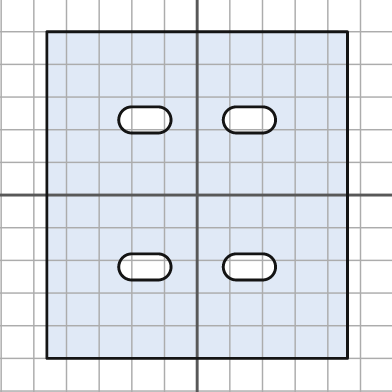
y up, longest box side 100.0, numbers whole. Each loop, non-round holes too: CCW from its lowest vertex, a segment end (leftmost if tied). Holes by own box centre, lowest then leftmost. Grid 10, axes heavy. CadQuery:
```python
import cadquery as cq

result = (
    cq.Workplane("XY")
    .moveTo(-46.0, -50.0)
    .lineTo(46.0, -50.0)
    .lineTo(46.0, 50.0)
    .lineTo(-46.0, 50.0)
    .close()
    .moveTo(-20.0, -26.0)
    .lineTo(-12.0, -26.0)
    .threePointArc((-8.0, -22.0), (-12.0, -18.0))
    .lineTo(-20.0, -18.0)
    .threePointArc((-24.0, -22.0), (-20.0, -26.0))
    .close()
    .moveTo(12.0, -26.0)
    .lineTo(20.0, -26.0)
    .threePointArc((24.0, -22.0), (20.0, -18.0))
    .lineTo(12.0, -18.0)
    .threePointArc((8.0, -22.0), (12.0, -26.0))
    .close()
    .moveTo(-20.0, 19.0)
    .lineTo(-12.0, 19.0)
    .threePointArc((-8.0, 23.0), (-12.0, 27.0))
    .lineTo(-20.0, 27.0)
    .threePointArc((-24.0, 23.0), (-20.0, 19.0))
    .close()
    .moveTo(12.0, 19.0)
    .lineTo(20.0, 19.0)
    .threePointArc((24.0, 23.0), (20.0, 27.0))
    .lineTo(12.0, 27.0)
    .threePointArc((8.0, 23.0), (12.0, 19.0))
    .close()
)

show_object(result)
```